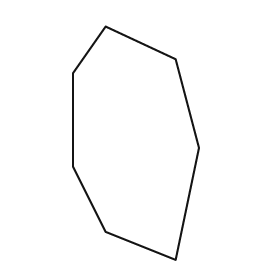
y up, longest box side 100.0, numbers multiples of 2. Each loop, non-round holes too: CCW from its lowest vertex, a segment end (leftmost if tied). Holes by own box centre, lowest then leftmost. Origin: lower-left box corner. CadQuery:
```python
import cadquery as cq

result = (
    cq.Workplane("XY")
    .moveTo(44.0, 0.0)
    .lineTo(54.0, 48.0)
    .lineTo(44.0, 86.0)
    .lineTo(14.0, 100.0)
    .lineTo(0.0, 80.0)
    .lineTo(0.0, 40.0)
    .lineTo(14.0, 12.0)
    .close()
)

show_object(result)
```